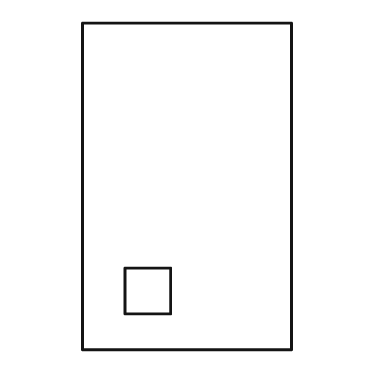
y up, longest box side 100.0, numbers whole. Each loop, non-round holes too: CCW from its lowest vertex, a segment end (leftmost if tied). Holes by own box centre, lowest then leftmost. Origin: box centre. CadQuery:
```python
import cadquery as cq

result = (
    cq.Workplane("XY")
    .moveTo(-32.0, -50.0)
    .lineTo(32.0, -50.0)
    .lineTo(32.0, 50.0)
    .lineTo(-32.0, 50.0)
    .close()
    .moveTo(-19.0, -39.0)
    .lineTo(-5.0, -39.0)
    .lineTo(-5.0, -25.0)
    .lineTo(-19.0, -25.0)
    .close()
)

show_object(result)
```